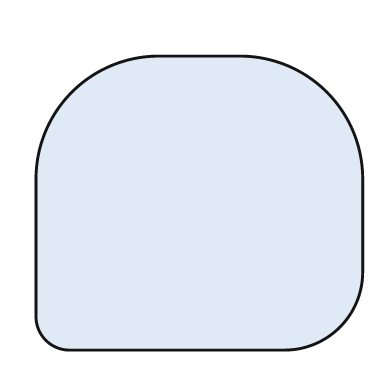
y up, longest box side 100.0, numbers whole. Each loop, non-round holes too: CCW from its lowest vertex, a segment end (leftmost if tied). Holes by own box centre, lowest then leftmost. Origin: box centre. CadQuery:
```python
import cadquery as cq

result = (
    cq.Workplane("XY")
    .moveTo(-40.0, -45.0)
    .lineTo(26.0, -45.0)
    .threePointArc((43.0, -38.0), (50.0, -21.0))
    .lineTo(50.0, 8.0)
    .threePointArc((39.0, 34.0), (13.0, 45.0))
    .lineTo(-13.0, 45.0)
    .threePointArc((-39.0, 34.0), (-50.0, 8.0))
    .lineTo(-50.0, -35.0)
    .threePointArc((-47.0, -42.0), (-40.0, -45.0))
    .close()
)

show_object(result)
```